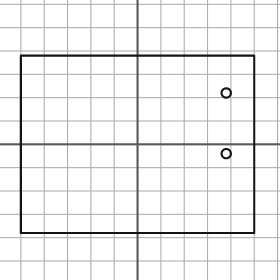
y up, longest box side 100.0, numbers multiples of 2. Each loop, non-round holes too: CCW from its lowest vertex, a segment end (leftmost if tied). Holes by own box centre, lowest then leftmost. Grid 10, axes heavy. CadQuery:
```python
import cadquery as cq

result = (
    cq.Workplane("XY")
    .moveTo(-50.0, -38.0)
    .lineTo(50.0, -38.0)
    .lineTo(50.0, 38.0)
    .lineTo(-50.0, 38.0)
    .close()
    .moveTo(38.0, -4.0)
    .circle(2.0)
    .moveTo(38.0, 22.0)
    .circle(2.0)
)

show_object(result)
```